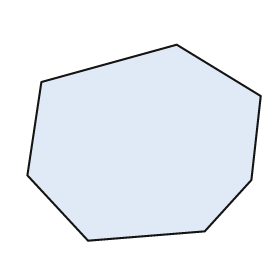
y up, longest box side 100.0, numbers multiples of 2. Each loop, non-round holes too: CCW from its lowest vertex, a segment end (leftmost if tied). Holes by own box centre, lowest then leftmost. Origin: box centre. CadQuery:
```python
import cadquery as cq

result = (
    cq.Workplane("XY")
    .moveTo(-24.0, -42.0)
    .lineTo(26.0, -38.0)
    .lineTo(46.0, -16.0)
    .lineTo(50.0, 20.0)
    .lineTo(14.0, 42.0)
    .lineTo(-44.0, 26.0)
    .lineTo(-50.0, -14.0)
    .close()
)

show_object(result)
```